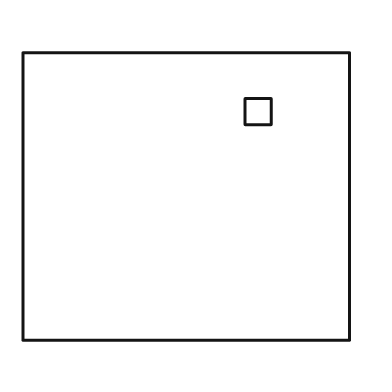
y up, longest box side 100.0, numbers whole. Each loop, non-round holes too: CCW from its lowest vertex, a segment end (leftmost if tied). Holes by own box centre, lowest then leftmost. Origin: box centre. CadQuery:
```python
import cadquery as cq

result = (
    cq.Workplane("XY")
    .moveTo(-50.0, -44.0)
    .lineTo(50.0, -44.0)
    .lineTo(50.0, 44.0)
    .lineTo(-50.0, 44.0)
    .close()
    .moveTo(18.0, 22.0)
    .lineTo(26.0, 22.0)
    .lineTo(26.0, 30.0)
    .lineTo(18.0, 30.0)
    .close()
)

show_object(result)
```